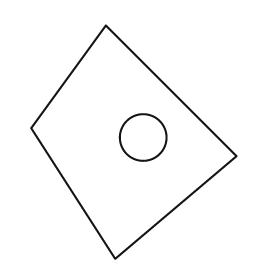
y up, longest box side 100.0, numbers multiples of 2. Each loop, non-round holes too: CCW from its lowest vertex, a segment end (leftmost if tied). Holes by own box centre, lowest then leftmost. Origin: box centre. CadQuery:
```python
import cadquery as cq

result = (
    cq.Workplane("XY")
    .moveTo(-8.0, -50.0)
    .lineTo(44.0, -6.0)
    .lineTo(-12.0, 50.0)
    .lineTo(-44.0, 6.0)
    .close()
    .moveTo(4.0, 2.0)
    .circle(10.0)
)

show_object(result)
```